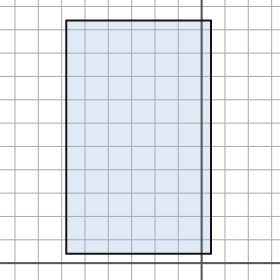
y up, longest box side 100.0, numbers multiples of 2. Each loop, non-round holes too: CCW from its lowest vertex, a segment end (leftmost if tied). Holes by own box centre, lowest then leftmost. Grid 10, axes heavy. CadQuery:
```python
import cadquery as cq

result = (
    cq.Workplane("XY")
    .moveTo(-58.0, 4.0)
    .lineTo(4.0, 4.0)
    .lineTo(4.0, 104.0)
    .lineTo(-58.0, 104.0)
    .close()
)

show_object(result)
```